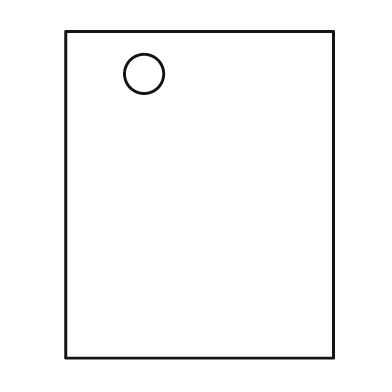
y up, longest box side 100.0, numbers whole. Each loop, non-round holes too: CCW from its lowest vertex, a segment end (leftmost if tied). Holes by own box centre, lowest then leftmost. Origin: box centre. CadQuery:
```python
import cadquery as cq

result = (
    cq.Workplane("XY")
    .moveTo(-41.0, -50.0)
    .lineTo(41.0, -50.0)
    .lineTo(41.0, 50.0)
    .lineTo(-41.0, 50.0)
    .close()
    .moveTo(-17.0, 37.0)
    .circle(6.0)
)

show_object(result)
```